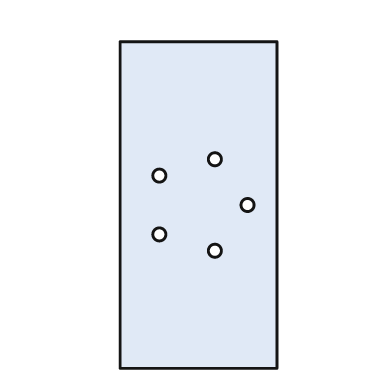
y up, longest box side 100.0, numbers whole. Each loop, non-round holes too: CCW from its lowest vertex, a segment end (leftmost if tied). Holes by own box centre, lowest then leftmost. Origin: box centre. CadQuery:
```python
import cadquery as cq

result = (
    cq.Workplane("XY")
    .moveTo(-24.0, -50.0)
    .lineTo(24.0, -50.0)
    .lineTo(24.0, 50.0)
    .lineTo(-24.0, 50.0)
    .close()
    .moveTo(5.0, -14.0)
    .circle(2.0)
    .moveTo(-12.0, -9.0)
    .circle(2.0)
    .moveTo(15.0, 0.0)
    .circle(2.0)
    .moveTo(-12.0, 9.0)
    .circle(2.0)
    .moveTo(5.0, 14.0)
    .circle(2.0)
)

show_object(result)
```